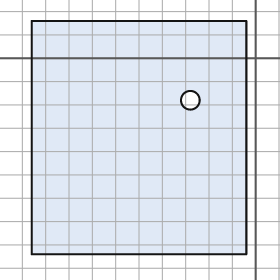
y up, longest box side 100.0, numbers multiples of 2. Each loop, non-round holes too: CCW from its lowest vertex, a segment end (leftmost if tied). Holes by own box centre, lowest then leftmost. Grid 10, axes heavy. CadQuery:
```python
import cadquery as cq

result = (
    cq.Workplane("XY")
    .moveTo(-96.0, -84.0)
    .lineTo(-4.0, -84.0)
    .lineTo(-4.0, 16.0)
    .lineTo(-96.0, 16.0)
    .close()
    .moveTo(-28.0, -18.0)
    .circle(4.0)
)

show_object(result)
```